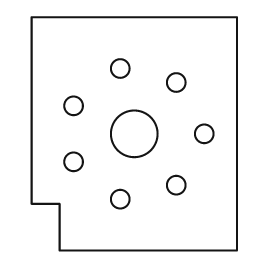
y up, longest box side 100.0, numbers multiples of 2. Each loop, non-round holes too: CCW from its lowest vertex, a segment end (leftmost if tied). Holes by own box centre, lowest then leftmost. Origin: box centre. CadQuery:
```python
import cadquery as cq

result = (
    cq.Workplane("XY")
    .moveTo(-32.0, -50.0)
    .lineTo(44.0, -50.0)
    .lineTo(44.0, 50.0)
    .lineTo(-44.0, 50.0)
    .lineTo(-44.0, -30.0)
    .lineTo(-32.0, -30.0)
    .close()
    .moveTo(-6.0, -28.0)
    .circle(4.0)
    .moveTo(18.0, -22.0)
    .circle(4.0)
    .moveTo(-26.0, -12.0)
    .circle(4.0)
    .moveTo(0.0, 0.0)
    .circle(10.0)
    .moveTo(30.0, 0.0)
    .circle(4.0)
    .moveTo(-26.0, 12.0)
    .circle(4.0)
    .moveTo(18.0, 22.0)
    .circle(4.0)
    .moveTo(-6.0, 28.0)
    .circle(4.0)
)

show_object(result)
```